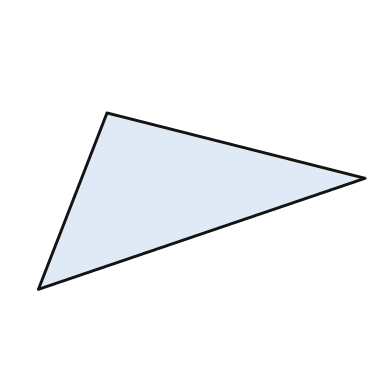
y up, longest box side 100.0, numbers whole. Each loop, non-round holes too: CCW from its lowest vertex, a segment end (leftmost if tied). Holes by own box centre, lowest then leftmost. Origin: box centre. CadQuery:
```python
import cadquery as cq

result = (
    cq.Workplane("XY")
    .moveTo(-50.0, -27.0)
    .lineTo(50.0, 7.0)
    .lineTo(-29.0, 27.0)
    .close()
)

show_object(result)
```